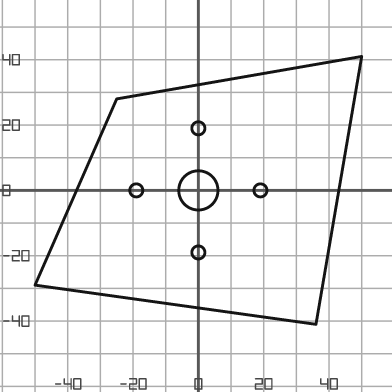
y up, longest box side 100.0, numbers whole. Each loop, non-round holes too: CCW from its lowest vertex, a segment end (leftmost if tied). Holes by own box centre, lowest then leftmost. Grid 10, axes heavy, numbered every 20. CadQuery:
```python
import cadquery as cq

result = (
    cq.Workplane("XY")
    .moveTo(36.0, -41.0)
    .lineTo(50.0, 41.0)
    .lineTo(-25.0, 28.0)
    .lineTo(-50.0, -29.0)
    .close()
    .moveTo(0.0, -19.0)
    .circle(2.0)
    .moveTo(-19.0, 0.0)
    .circle(2.0)
    .moveTo(0.0, 0.0)
    .circle(6.0)
    .moveTo(19.0, 0.0)
    .circle(2.0)
    .moveTo(0.0, 19.0)
    .circle(2.0)
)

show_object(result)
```